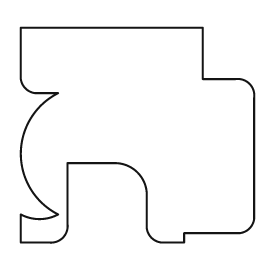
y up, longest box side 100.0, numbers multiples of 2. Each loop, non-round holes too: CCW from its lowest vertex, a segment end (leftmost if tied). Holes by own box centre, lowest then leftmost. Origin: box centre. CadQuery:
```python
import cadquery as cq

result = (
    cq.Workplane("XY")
    .moveTo(-50.0, -46.0)
    .lineTo(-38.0, -46.0)
    .threePointArc((-32.0, -44.0), (-30.0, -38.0))
    .lineTo(-30.0, -12.0)
    .lineTo(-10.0, -12.0)
    .threePointArc((0.0, -16.0), (4.0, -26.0))
    .lineTo(4.0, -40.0)
    .threePointArc((6.0, -44.0), (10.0, -46.0))
    .lineTo(20.0, -46.0)
    .lineTo(20.0, -42.0)
    .lineTo(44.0, -42.0)
    .threePointArc((48.0, -40.0), (50.0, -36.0))
    .lineTo(50.0, 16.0)
    .threePointArc((48.0, 22.0), (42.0, 24.0))
    .lineTo(28.0, 24.0)
    .lineTo(28.0, 46.0)
    .lineTo(-50.0, 46.0)
    .lineTo(-50.0, 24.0)
    .threePointArc((-48.0, 20.0), (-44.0, 18.0))
    .lineTo(-34.0, 18.0)
    .threePointArc((-50.0, -8.0), (-34.0, -34.0))
    .threePointArc((-42.0, -36.0), (-50.0, -34.0))
    .close()
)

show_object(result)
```